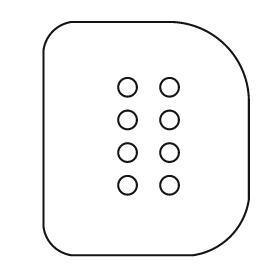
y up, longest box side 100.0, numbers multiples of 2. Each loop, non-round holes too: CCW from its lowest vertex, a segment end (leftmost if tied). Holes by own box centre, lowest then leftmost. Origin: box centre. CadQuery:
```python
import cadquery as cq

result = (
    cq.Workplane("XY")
    .moveTo(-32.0, -50.0)
    .lineTo(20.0, -50.0)
    .threePointArc((36.0, -42.0), (44.0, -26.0))
    .lineTo(44.0, 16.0)
    .threePointArc((34.0, 40.0), (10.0, 50.0))
    .lineTo(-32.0, 50.0)
    .threePointArc((-40.0, 46.0), (-44.0, 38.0))
    .lineTo(-44.0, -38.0)
    .threePointArc((-40.0, -46.0), (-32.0, -50.0))
    .close()
    .moveTo(-8.0, -20.0)
    .circle(4.0)
    .moveTo(10.0, -20.0)
    .circle(4.0)
    .moveTo(-8.0, -6.0)
    .circle(4.0)
    .moveTo(10.0, -6.0)
    .circle(4.0)
    .moveTo(-8.0, 8.0)
    .circle(4.0)
    .moveTo(10.0, 8.0)
    .circle(4.0)
    .moveTo(-8.0, 22.0)
    .circle(4.0)
    .moveTo(10.0, 22.0)
    .circle(4.0)
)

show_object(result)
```